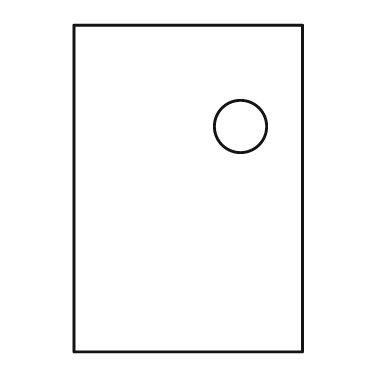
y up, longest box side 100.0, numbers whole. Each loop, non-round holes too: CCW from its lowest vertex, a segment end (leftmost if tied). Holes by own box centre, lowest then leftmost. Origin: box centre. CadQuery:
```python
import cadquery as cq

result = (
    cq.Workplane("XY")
    .moveTo(-35.0, -50.0)
    .lineTo(35.0, -50.0)
    .lineTo(35.0, 50.0)
    .lineTo(-35.0, 50.0)
    .close()
    .moveTo(16.0, 19.0)
    .circle(8.0)
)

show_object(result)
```